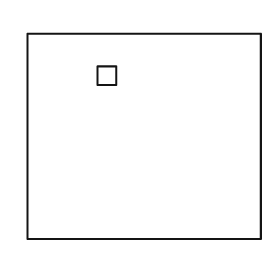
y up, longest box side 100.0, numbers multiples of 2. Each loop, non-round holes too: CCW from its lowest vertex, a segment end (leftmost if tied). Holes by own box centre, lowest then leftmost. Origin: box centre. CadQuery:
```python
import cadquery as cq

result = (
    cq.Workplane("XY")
    .moveTo(-50.0, -44.0)
    .lineTo(50.0, -44.0)
    .lineTo(50.0, 44.0)
    .lineTo(-50.0, 44.0)
    .close()
    .moveTo(-20.0, 22.0)
    .lineTo(-12.0, 22.0)
    .lineTo(-12.0, 30.0)
    .lineTo(-20.0, 30.0)
    .close()
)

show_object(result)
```